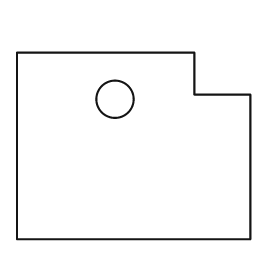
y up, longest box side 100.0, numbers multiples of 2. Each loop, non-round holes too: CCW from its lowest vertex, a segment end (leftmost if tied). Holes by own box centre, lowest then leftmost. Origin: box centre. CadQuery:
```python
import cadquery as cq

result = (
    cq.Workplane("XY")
    .moveTo(-50.0, -40.0)
    .lineTo(50.0, -40.0)
    .lineTo(50.0, 22.0)
    .lineTo(26.0, 22.0)
    .lineTo(26.0, 40.0)
    .lineTo(-50.0, 40.0)
    .close()
    .moveTo(-8.0, 20.0)
    .circle(8.0)
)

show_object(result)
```